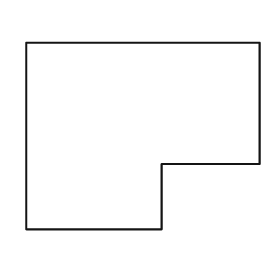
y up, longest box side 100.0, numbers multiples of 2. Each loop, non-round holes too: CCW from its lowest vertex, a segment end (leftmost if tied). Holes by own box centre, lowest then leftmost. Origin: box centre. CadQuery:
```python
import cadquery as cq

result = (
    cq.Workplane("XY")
    .moveTo(-50.0, -40.0)
    .lineTo(8.0, -40.0)
    .lineTo(8.0, -12.0)
    .lineTo(50.0, -12.0)
    .lineTo(50.0, 40.0)
    .lineTo(-50.0, 40.0)
    .close()
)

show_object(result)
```